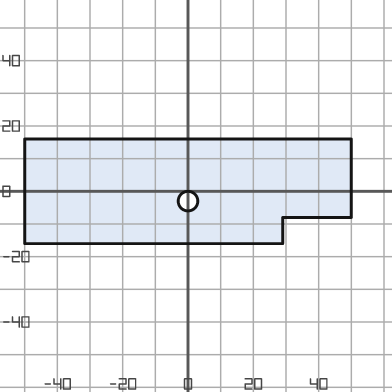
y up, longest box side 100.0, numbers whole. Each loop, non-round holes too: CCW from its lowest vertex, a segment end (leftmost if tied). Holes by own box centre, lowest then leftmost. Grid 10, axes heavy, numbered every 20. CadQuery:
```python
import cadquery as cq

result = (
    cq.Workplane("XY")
    .moveTo(-50.0, -16.0)
    .lineTo(29.0, -16.0)
    .lineTo(29.0, -8.0)
    .lineTo(50.0, -8.0)
    .lineTo(50.0, 16.0)
    .lineTo(-50.0, 16.0)
    .close()
    .moveTo(0.0, -3.0)
    .circle(3.0)
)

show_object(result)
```